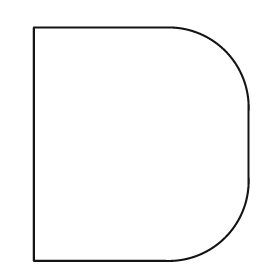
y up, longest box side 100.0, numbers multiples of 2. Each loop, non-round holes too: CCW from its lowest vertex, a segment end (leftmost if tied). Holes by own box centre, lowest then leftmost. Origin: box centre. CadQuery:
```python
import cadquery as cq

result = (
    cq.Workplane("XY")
    .moveTo(-46.0, -50.0)
    .lineTo(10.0, -50.0)
    .threePointArc((36.0, -40.0), (46.0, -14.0))
    .lineTo(46.0, 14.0)
    .threePointArc((36.0, 40.0), (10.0, 50.0))
    .lineTo(-46.0, 50.0)
    .close()
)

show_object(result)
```